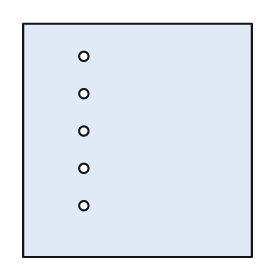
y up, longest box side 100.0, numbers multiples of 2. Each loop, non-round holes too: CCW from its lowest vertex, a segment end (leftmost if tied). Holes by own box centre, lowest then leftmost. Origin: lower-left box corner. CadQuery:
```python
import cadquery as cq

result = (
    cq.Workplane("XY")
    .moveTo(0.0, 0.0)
    .lineTo(98.0, 0.0)
    .lineTo(98.0, 100.0)
    .lineTo(0.0, 100.0)
    .close()
    .moveTo(26.0, 22.0)
    .circle(2.0)
    .moveTo(26.0, 38.0)
    .circle(2.0)
    .moveTo(26.0, 54.0)
    .circle(2.0)
    .moveTo(26.0, 70.0)
    .circle(2.0)
    .moveTo(26.0, 86.0)
    .circle(2.0)
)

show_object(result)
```